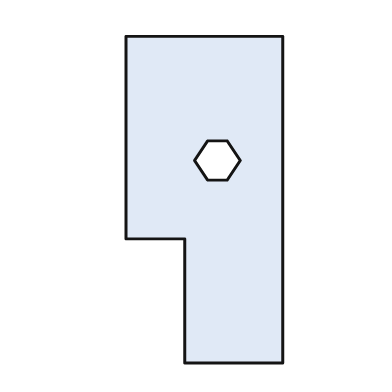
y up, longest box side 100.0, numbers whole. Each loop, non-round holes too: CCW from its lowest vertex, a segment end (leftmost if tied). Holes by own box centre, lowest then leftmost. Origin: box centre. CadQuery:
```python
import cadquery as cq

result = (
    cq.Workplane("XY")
    .moveTo(-6.0, -50.0)
    .lineTo(24.0, -50.0)
    .lineTo(24.0, 50.0)
    .lineTo(-24.0, 50.0)
    .lineTo(-24.0, -12.0)
    .lineTo(-6.0, -12.0)
    .close()
    .moveTo(1.0, 6.0)
    .lineTo(7.0, 6.0)
    .lineTo(11.0, 12.0)
    .lineTo(7.0, 18.0)
    .lineTo(1.0, 18.0)
    .lineTo(-3.0, 12.0)
    .close()
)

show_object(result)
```